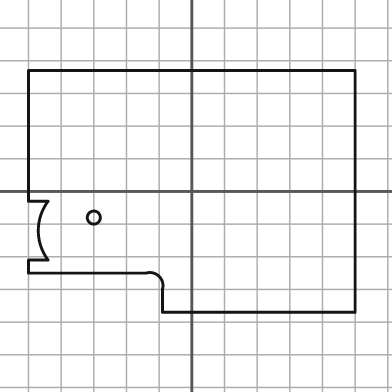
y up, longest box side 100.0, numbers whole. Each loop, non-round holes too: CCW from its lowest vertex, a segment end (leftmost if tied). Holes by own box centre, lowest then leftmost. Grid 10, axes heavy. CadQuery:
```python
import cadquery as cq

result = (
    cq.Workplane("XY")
    .moveTo(-9.0, -37.0)
    .lineTo(50.0, -37.0)
    .lineTo(50.0, 37.0)
    .lineTo(-50.0, 37.0)
    .lineTo(-50.0, -3.0)
    .lineTo(-44.0, -3.0)
    .threePointArc((-47.0, -12.0), (-44.0, -21.0))
    .lineTo(-50.0, -21.0)
    .lineTo(-50.0, -25.0)
    .lineTo(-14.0, -25.0)
    .threePointArc((-10.0, -26.0), (-9.0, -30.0))
    .close()
    .moveTo(-30.0, -8.0)
    .circle(2.0)
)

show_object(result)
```